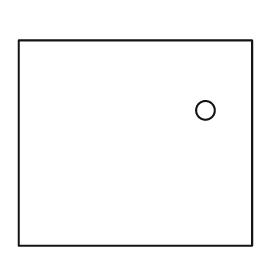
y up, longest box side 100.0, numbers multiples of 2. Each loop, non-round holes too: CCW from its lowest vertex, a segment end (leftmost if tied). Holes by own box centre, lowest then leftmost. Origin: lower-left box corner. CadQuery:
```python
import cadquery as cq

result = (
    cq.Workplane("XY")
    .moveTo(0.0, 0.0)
    .lineTo(100.0, 0.0)
    .lineTo(100.0, 88.0)
    .lineTo(0.0, 88.0)
    .close()
    .moveTo(80.0, 58.0)
    .circle(4.0)
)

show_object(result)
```